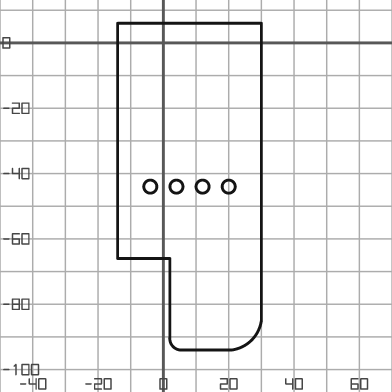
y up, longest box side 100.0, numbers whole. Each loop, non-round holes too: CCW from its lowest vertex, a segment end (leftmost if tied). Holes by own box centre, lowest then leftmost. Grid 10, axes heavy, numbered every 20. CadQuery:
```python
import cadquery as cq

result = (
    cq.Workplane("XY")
    .moveTo(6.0, -94.0)
    .lineTo(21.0, -94.0)
    .threePointArc((27.0, -91.0), (30.0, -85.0))
    .lineTo(30.0, 6.0)
    .lineTo(-14.0, 6.0)
    .lineTo(-14.0, -66.0)
    .lineTo(2.0, -66.0)
    .lineTo(2.0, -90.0)
    .threePointArc((3.0, -93.0), (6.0, -94.0))
    .close()
    .moveTo(-4.0, -44.0)
    .circle(2.0)
    .moveTo(4.0, -44.0)
    .circle(2.0)
    .moveTo(12.0, -44.0)
    .circle(2.0)
    .moveTo(20.0, -44.0)
    .circle(2.0)
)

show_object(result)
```